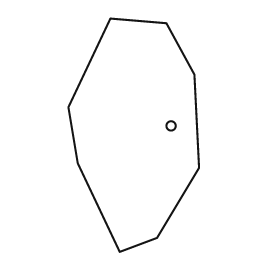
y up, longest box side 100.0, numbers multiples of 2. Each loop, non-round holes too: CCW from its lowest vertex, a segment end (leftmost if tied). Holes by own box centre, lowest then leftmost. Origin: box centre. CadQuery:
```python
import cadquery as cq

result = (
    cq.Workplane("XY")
    .moveTo(-6.0, -50.0)
    .lineTo(10.0, -44.0)
    .lineTo(28.0, -14.0)
    .lineTo(26.0, 26.0)
    .lineTo(14.0, 48.0)
    .lineTo(-10.0, 50.0)
    .lineTo(-28.0, 12.0)
    .lineTo(-24.0, -12.0)
    .close()
    .moveTo(16.0, 4.0)
    .circle(2.0)
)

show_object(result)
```